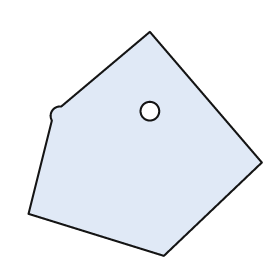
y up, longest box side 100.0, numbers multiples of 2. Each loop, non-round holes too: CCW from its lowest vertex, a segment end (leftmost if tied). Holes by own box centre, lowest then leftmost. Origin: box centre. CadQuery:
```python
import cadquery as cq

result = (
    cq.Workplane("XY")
    .moveTo(8.0, -48.0)
    .lineTo(50.0, -8.0)
    .lineTo(2.0, 48.0)
    .lineTo(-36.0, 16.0)
    .threePointArc((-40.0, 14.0), (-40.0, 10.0))
    .lineTo(-50.0, -30.0)
    .close()
    .moveTo(2.0, 14.0)
    .circle(4.0)
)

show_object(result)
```